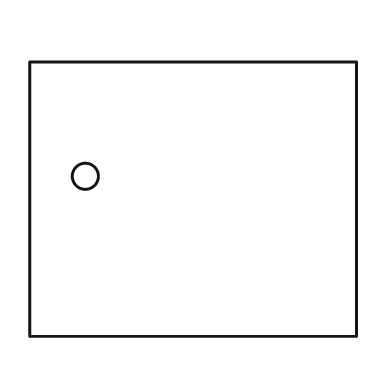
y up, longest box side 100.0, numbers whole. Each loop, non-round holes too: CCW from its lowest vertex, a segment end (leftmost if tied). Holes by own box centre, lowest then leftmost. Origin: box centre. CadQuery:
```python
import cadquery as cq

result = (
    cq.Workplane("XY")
    .moveTo(-50.0, -42.0)
    .lineTo(50.0, -42.0)
    .lineTo(50.0, 42.0)
    .lineTo(-50.0, 42.0)
    .close()
    .moveTo(-33.0, 7.0)
    .circle(4.0)
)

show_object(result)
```